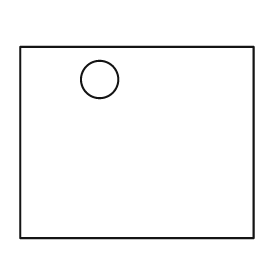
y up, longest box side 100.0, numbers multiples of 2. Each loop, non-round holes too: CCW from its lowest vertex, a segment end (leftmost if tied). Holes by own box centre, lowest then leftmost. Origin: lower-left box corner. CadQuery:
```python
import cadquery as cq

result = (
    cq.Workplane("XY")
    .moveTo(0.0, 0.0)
    .lineTo(100.0, 0.0)
    .lineTo(100.0, 82.0)
    .lineTo(0.0, 82.0)
    .close()
    .moveTo(34.0, 68.0)
    .circle(8.0)
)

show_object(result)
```